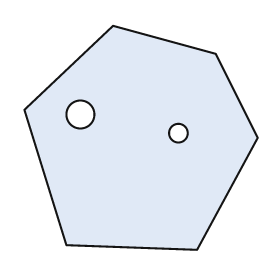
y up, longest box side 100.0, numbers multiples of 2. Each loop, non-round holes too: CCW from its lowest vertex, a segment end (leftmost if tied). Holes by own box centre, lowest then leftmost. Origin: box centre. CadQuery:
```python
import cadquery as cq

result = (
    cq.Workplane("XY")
    .moveTo(24.0, -48.0)
    .lineTo(50.0, 0.0)
    .lineTo(32.0, 36.0)
    .lineTo(-12.0, 48.0)
    .lineTo(-50.0, 12.0)
    .lineTo(-32.0, -46.0)
    .close()
    .moveTo(16.0, 2.0)
    .circle(4.0)
    .moveTo(-26.0, 10.0)
    .circle(6.0)
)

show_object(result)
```